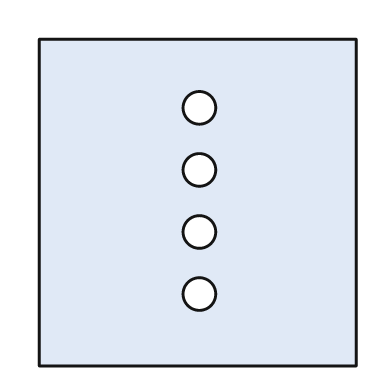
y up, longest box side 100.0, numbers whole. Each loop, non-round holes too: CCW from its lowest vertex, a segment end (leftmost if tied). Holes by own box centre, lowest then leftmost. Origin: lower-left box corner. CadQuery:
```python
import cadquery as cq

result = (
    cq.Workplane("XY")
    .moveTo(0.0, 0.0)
    .lineTo(97.0, 0.0)
    .lineTo(97.0, 100.0)
    .lineTo(0.0, 100.0)
    .close()
    .moveTo(49.0, 22.0)
    .circle(5.0)
    .moveTo(49.0, 41.0)
    .circle(5.0)
    .moveTo(49.0, 60.0)
    .circle(5.0)
    .moveTo(49.0, 79.0)
    .circle(5.0)
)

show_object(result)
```